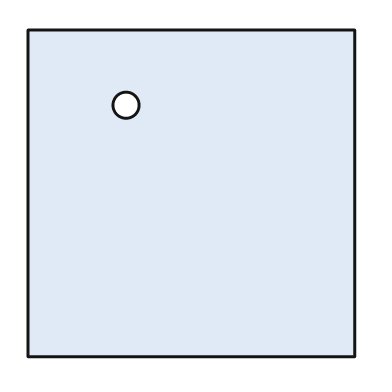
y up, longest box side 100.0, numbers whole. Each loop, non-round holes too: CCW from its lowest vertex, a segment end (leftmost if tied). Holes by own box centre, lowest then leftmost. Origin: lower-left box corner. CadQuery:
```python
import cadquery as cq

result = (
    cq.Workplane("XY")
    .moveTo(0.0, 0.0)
    .lineTo(100.0, 0.0)
    .lineTo(100.0, 100.0)
    .lineTo(0.0, 100.0)
    .close()
    .moveTo(30.0, 77.0)
    .circle(4.0)
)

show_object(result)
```